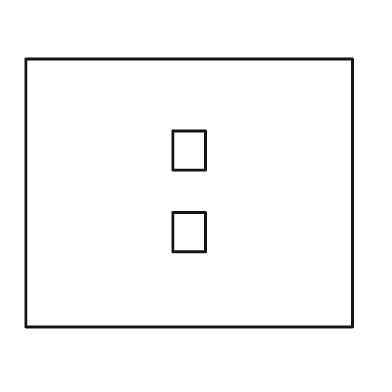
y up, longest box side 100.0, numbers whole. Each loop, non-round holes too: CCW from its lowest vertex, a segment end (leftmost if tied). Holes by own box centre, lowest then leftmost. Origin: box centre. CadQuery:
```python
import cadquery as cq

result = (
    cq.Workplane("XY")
    .moveTo(-50.0, -41.0)
    .lineTo(50.0, -41.0)
    .lineTo(50.0, 41.0)
    .lineTo(-50.0, 41.0)
    .close()
    .moveTo(-5.0, -18.0)
    .lineTo(5.0, -18.0)
    .lineTo(5.0, -6.0)
    .lineTo(-5.0, -6.0)
    .close()
    .moveTo(-5.0, 7.0)
    .lineTo(5.0, 7.0)
    .lineTo(5.0, 19.0)
    .lineTo(-5.0, 19.0)
    .close()
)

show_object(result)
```